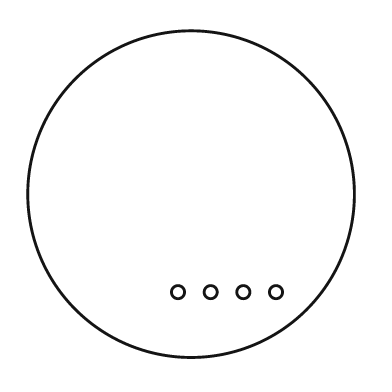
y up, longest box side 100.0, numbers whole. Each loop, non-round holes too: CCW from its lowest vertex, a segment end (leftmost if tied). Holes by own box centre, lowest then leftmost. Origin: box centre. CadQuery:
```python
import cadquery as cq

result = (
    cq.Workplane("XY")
    .moveTo(0.0, 0.0)
    .circle(50.0)
    .moveTo(-4.0, -30.0)
    .circle(2.0)
    .moveTo(6.0, -30.0)
    .circle(2.0)
    .moveTo(16.0, -30.0)
    .circle(2.0)
    .moveTo(26.0, -30.0)
    .circle(2.0)
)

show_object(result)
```